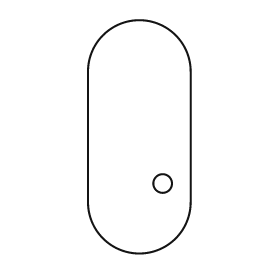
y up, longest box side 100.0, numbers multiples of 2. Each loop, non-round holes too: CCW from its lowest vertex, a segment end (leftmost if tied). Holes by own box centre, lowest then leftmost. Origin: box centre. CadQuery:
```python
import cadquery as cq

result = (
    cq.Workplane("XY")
    .moveTo(-22.0, -28.0)
    .threePointArc((0.0, -50.0), (22.0, -28.0))
    .lineTo(22.0, 28.0)
    .threePointArc((0.0, 50.0), (-22.0, 28.0))
    .close()
    .moveTo(10.0, -20.0)
    .circle(4.0)
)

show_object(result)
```